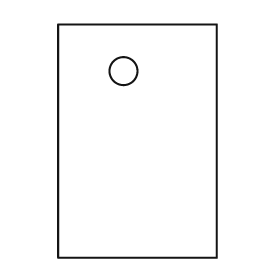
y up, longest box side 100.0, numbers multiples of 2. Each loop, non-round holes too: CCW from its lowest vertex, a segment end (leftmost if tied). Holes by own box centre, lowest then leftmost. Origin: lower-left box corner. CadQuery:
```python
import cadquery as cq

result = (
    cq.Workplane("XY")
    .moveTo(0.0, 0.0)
    .lineTo(68.0, 0.0)
    .lineTo(68.0, 100.0)
    .lineTo(0.0, 100.0)
    .close()
    .moveTo(28.0, 80.0)
    .circle(6.0)
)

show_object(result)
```